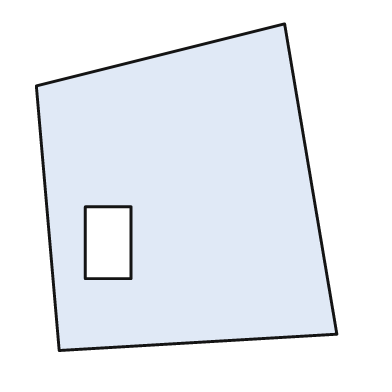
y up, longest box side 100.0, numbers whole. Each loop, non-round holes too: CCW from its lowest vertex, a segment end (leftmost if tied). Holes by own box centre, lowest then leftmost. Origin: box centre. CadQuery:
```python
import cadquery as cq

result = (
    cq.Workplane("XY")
    .moveTo(-39.0, -50.0)
    .lineTo(46.0, -45.0)
    .lineTo(30.0, 50.0)
    .lineTo(-46.0, 31.0)
    .close()
    .moveTo(-31.0, -28.0)
    .lineTo(-17.0, -28.0)
    .lineTo(-17.0, -6.0)
    .lineTo(-31.0, -6.0)
    .close()
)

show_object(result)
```